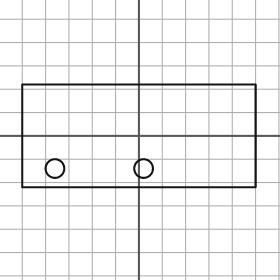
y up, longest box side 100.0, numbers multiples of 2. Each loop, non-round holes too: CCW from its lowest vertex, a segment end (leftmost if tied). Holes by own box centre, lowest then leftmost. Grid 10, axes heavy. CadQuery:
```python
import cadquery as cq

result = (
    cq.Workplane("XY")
    .moveTo(-50.0, -22.0)
    .lineTo(50.0, -22.0)
    .lineTo(50.0, 22.0)
    .lineTo(-50.0, 22.0)
    .close()
    .moveTo(-36.0, -14.0)
    .circle(4.0)
    .moveTo(2.0, -14.0)
    .circle(4.0)
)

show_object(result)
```